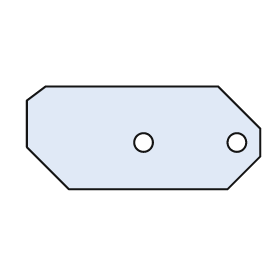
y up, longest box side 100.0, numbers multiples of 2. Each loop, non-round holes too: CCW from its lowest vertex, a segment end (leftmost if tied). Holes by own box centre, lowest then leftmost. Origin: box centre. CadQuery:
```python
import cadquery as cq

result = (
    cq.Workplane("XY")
    .moveTo(-32.0, -22.0)
    .lineTo(36.0, -22.0)
    .lineTo(50.0, -8.0)
    .lineTo(50.0, 4.0)
    .lineTo(32.0, 22.0)
    .lineTo(-42.0, 22.0)
    .lineTo(-50.0, 16.0)
    .lineTo(-50.0, -4.0)
    .close()
    .moveTo(0.0, -2.0)
    .circle(4.0)
    .moveTo(40.0, -2.0)
    .circle(4.0)
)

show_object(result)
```